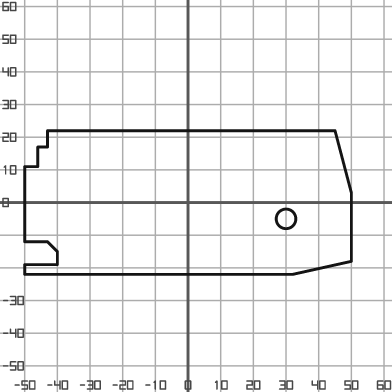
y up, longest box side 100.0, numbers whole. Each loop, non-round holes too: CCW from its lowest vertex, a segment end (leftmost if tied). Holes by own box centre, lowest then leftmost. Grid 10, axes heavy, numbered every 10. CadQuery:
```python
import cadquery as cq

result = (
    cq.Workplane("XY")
    .moveTo(-50.0, -22.0)
    .lineTo(32.0, -22.0)
    .lineTo(50.0, -18.0)
    .lineTo(50.0, 3.0)
    .lineTo(45.0, 22.0)
    .lineTo(-43.0, 22.0)
    .lineTo(-43.0, 17.0)
    .lineTo(-46.0, 17.0)
    .lineTo(-46.0, 11.0)
    .lineTo(-50.0, 11.0)
    .lineTo(-50.0, -12.0)
    .lineTo(-43.0, -12.0)
    .lineTo(-40.0, -15.0)
    .lineTo(-40.0, -19.0)
    .lineTo(-50.0, -19.0)
    .close()
    .moveTo(30.0, -5.0)
    .circle(3.0)
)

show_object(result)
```